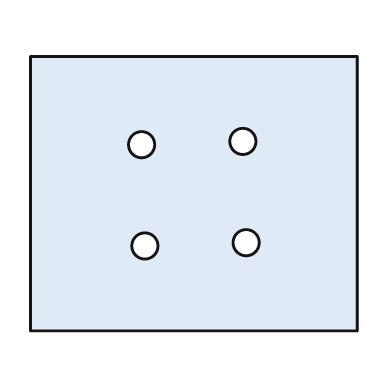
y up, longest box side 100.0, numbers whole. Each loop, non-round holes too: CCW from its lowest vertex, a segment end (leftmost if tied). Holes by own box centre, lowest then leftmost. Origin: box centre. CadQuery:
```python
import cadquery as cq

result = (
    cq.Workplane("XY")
    .moveTo(-50.0, -42.0)
    .lineTo(50.0, -42.0)
    .lineTo(50.0, 42.0)
    .lineTo(-50.0, 42.0)
    .close()
    .moveTo(-15.0, -16.0)
    .circle(4.0)
    .moveTo(16.0, -15.0)
    .circle(4.0)
    .moveTo(-16.0, 15.0)
    .circle(4.0)
    .moveTo(15.0, 16.0)
    .circle(4.0)
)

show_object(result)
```